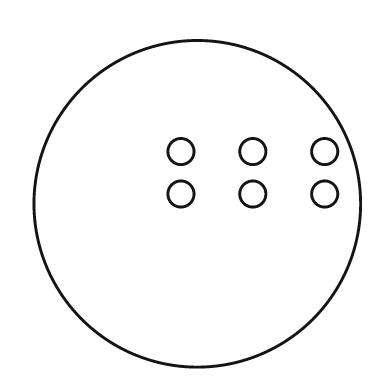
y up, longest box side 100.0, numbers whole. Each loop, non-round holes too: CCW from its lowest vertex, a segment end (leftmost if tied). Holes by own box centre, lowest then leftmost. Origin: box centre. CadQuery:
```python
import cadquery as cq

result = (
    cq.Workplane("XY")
    .moveTo(0.0, 0.0)
    .circle(50.0)
    .moveTo(-5.0, 3.0)
    .circle(4.0)
    .moveTo(17.0, 3.0)
    .circle(4.0)
    .moveTo(39.0, 3.0)
    .circle(4.0)
    .moveTo(-5.0, 16.0)
    .circle(4.0)
    .moveTo(17.0, 16.0)
    .circle(4.0)
    .moveTo(39.0, 16.0)
    .circle(4.0)
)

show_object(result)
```